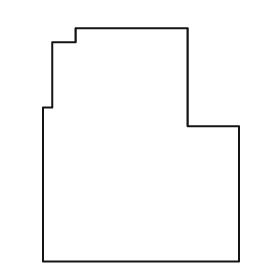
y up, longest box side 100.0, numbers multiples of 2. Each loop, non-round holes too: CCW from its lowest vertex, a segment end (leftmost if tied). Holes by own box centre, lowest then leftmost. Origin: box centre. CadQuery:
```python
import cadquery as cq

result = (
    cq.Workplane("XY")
    .moveTo(-42.0, -50.0)
    .lineTo(42.0, -50.0)
    .lineTo(42.0, 8.0)
    .lineTo(20.0, 8.0)
    .lineTo(20.0, 50.0)
    .lineTo(-28.0, 50.0)
    .lineTo(-28.0, 44.0)
    .lineTo(-38.0, 44.0)
    .lineTo(-38.0, 16.0)
    .lineTo(-42.0, 16.0)
    .close()
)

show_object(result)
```